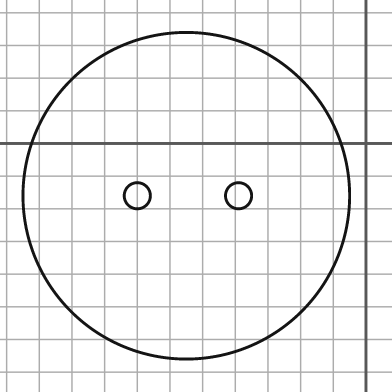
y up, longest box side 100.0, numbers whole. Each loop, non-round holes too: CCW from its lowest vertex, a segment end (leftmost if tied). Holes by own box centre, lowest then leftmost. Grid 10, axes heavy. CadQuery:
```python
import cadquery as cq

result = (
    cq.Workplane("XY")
    .moveTo(-55.0, -16.0)
    .circle(50.0)
    .moveTo(-70.0, -16.0)
    .circle(4.0)
    .moveTo(-39.0, -16.0)
    .circle(4.0)
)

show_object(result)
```